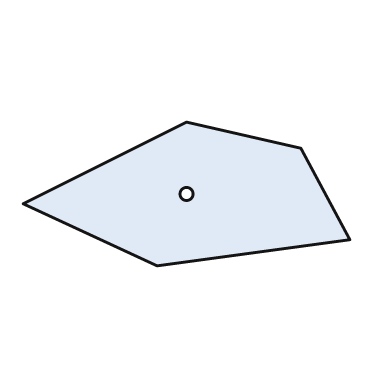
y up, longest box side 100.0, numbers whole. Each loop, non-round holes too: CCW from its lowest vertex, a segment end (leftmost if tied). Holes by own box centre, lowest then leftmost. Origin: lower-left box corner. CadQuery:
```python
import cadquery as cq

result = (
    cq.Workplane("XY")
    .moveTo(41.0, 0.0)
    .lineTo(100.0, 8.0)
    .lineTo(85.0, 36.0)
    .lineTo(50.0, 44.0)
    .lineTo(0.0, 19.0)
    .close()
    .moveTo(50.0, 22.0)
    .circle(2.0)
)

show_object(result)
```